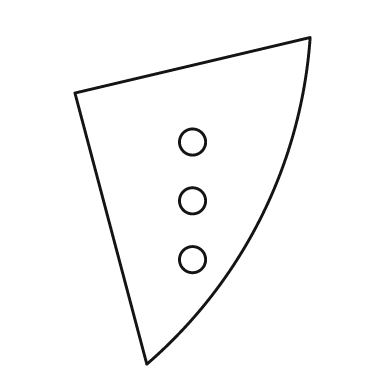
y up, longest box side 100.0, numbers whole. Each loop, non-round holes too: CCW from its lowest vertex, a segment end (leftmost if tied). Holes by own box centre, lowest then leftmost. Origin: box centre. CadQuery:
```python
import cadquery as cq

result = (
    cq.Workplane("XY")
    .moveTo(-14.0, -50.0)
    .threePointArc((21.0, -5.0), (36.0, 50.0))
    .lineTo(-36.0, 33.0)
    .close()
    .moveTo(0.0, -18.0)
    .circle(4.0)
    .moveTo(0.0, 0.0)
    .circle(4.0)
    .moveTo(0.0, 18.0)
    .circle(4.0)
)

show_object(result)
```